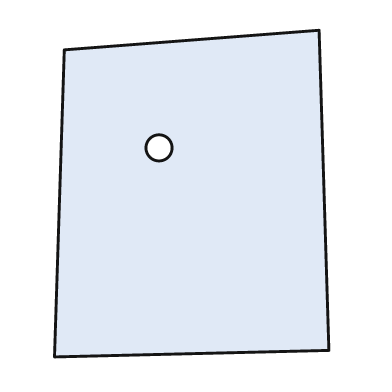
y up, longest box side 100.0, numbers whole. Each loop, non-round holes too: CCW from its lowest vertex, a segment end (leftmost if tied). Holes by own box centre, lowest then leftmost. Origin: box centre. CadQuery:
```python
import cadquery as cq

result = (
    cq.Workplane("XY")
    .moveTo(-42.0, -50.0)
    .lineTo(42.0, -48.0)
    .lineTo(39.0, 50.0)
    .lineTo(-39.0, 44.0)
    .close()
    .moveTo(-10.0, 14.0)
    .circle(4.0)
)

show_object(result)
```